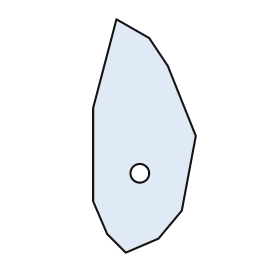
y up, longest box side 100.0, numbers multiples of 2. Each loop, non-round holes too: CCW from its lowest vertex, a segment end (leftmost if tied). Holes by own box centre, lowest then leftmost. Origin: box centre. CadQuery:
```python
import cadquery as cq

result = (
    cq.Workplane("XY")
    .moveTo(-8.0, -50.0)
    .lineTo(6.0, -44.0)
    .lineTo(16.0, -32.0)
    .lineTo(22.0, 0.0)
    .lineTo(10.0, 30.0)
    .lineTo(2.0, 42.0)
    .lineTo(-12.0, 50.0)
    .lineTo(-22.0, 12.0)
    .lineTo(-22.0, -28.0)
    .lineTo(-16.0, -42.0)
    .close()
    .moveTo(-2.0, -16.0)
    .circle(4.0)
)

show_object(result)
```